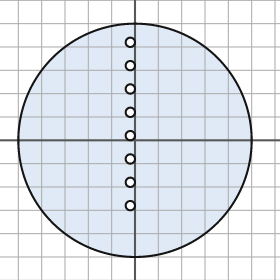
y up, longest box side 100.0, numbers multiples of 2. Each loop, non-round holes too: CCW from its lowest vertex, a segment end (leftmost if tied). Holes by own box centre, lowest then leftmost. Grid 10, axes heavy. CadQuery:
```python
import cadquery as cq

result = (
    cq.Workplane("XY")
    .moveTo(0.0, 0.0)
    .circle(50.0)
    .moveTo(-2.0, -28.0)
    .circle(2.0)
    .moveTo(-2.0, -18.0)
    .circle(2.0)
    .moveTo(-2.0, -8.0)
    .circle(2.0)
    .moveTo(-2.0, 2.0)
    .circle(2.0)
    .moveTo(-2.0, 12.0)
    .circle(2.0)
    .moveTo(-2.0, 22.0)
    .circle(2.0)
    .moveTo(-2.0, 32.0)
    .circle(2.0)
    .moveTo(-2.0, 42.0)
    .circle(2.0)
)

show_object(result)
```